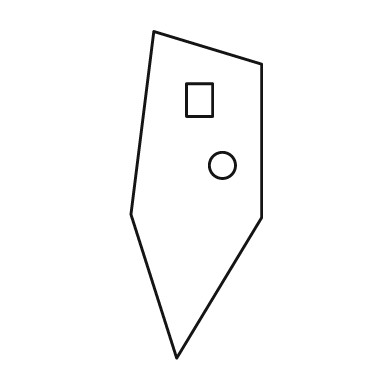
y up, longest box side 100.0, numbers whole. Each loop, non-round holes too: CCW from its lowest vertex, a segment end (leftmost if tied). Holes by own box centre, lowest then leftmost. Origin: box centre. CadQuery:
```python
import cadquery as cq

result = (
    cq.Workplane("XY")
    .moveTo(-6.0, -50.0)
    .lineTo(20.0, -7.0)
    .lineTo(20.0, 40.0)
    .lineTo(-13.0, 50.0)
    .lineTo(-20.0, -6.0)
    .close()
    .moveTo(8.0, 9.0)
    .circle(4.0)
    .moveTo(-3.0, 24.0)
    .lineTo(5.0, 24.0)
    .lineTo(5.0, 34.0)
    .lineTo(-3.0, 34.0)
    .close()
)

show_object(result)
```